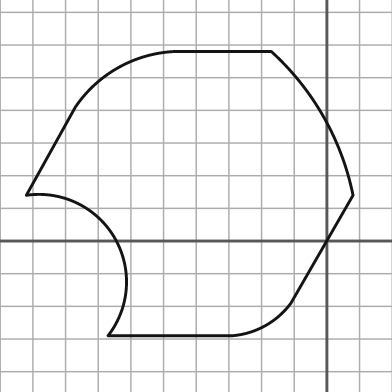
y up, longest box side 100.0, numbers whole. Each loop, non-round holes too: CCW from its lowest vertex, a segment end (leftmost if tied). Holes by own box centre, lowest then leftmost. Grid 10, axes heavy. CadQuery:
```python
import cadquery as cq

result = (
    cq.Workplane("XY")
    .moveTo(-67.0, -29.0)
    .lineTo(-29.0, -29.0)
    .threePointArc((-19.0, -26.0), (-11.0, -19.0))
    .lineTo(8.0, 14.0)
    .threePointArc((-1.0, 38.0), (-17.0, 58.0))
    .lineTo(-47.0, 58.0)
    .threePointArc((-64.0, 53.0), (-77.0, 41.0))
    .lineTo(-92.0, 14.0)
    .threePointArc((-65.0, 1.0), (-67.0, -29.0))
    .close()
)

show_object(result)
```